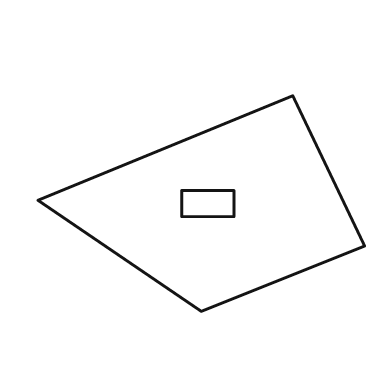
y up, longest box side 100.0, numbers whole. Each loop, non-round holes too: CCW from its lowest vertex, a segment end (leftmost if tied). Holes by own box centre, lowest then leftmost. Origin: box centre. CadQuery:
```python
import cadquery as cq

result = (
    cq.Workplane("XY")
    .moveTo(0.0, -33.0)
    .lineTo(50.0, -13.0)
    .lineTo(28.0, 33.0)
    .lineTo(-50.0, 1.0)
    .close()
    .moveTo(-6.0, -4.0)
    .lineTo(10.0, -4.0)
    .lineTo(10.0, 4.0)
    .lineTo(-6.0, 4.0)
    .close()
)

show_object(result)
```